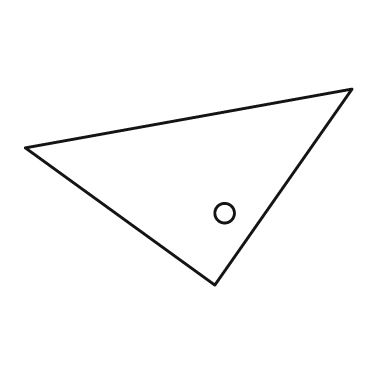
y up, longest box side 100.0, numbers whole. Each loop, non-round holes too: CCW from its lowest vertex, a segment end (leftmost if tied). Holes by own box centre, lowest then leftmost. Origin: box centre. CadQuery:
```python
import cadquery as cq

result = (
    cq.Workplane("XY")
    .moveTo(8.0, -30.0)
    .lineTo(50.0, 30.0)
    .lineTo(-50.0, 12.0)
    .close()
    .moveTo(11.0, -8.0)
    .circle(3.0)
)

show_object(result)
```